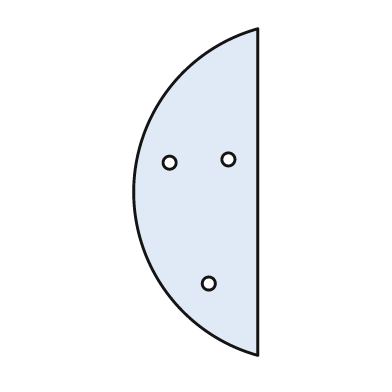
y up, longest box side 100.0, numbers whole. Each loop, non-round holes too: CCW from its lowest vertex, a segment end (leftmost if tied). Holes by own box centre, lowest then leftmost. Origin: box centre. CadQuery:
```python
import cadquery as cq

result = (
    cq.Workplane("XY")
    .moveTo(19.0, -50.0)
    .lineTo(19.0, 50.0)
    .threePointArc((-19.0, 0.0), (19.0, -50.0))
    .close()
    .moveTo(4.0, -28.0)
    .circle(2.0)
    .moveTo(-8.0, 9.0)
    .circle(2.0)
    .moveTo(10.0, 10.0)
    .circle(2.0)
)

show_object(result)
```